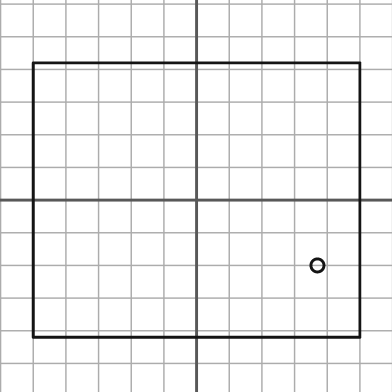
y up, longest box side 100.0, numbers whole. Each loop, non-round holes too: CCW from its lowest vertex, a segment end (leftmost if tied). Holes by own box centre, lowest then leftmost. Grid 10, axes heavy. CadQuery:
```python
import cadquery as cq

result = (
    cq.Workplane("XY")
    .moveTo(-50.0, -42.0)
    .lineTo(50.0, -42.0)
    .lineTo(50.0, 42.0)
    .lineTo(-50.0, 42.0)
    .close()
    .moveTo(37.0, -20.0)
    .circle(2.0)
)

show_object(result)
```